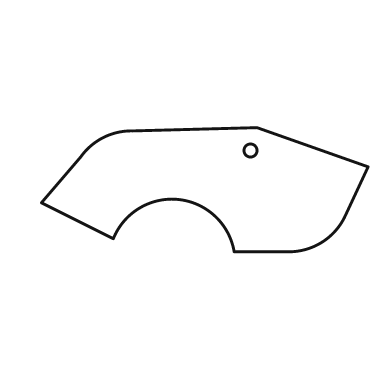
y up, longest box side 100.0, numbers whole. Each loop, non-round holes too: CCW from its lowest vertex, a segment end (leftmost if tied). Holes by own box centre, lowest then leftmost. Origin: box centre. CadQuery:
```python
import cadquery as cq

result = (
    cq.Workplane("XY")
    .moveTo(9.0, -19.0)
    .lineTo(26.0, -19.0)
    .threePointArc((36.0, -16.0), (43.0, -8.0))
    .lineTo(50.0, 7.0)
    .lineTo(16.0, 19.0)
    .lineTo(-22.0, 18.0)
    .threePointArc((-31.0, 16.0), (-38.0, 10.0))
    .lineTo(-50.0, -4.0)
    .lineTo(-28.0, -15.0)
    .threePointArc((-8.0, -3.0), (9.0, -19.0))
    .close()
    .moveTo(14.0, 12.0)
    .circle(2.0)
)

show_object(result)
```